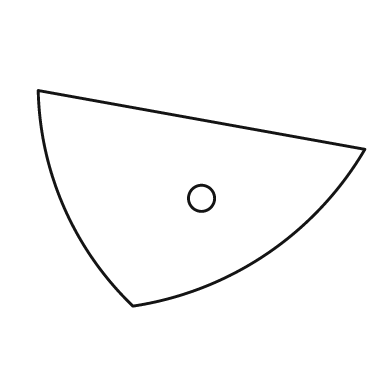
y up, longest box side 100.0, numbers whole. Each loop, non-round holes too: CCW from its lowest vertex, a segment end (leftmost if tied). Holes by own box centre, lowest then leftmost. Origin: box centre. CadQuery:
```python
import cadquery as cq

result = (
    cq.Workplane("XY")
    .moveTo(-21.0, -33.0)
    .threePointArc((20.0, -17.0), (50.0, 15.0))
    .lineTo(-50.0, 33.0)
    .threePointArc((-42.0, -3.0), (-21.0, -33.0))
    .close()
    .moveTo(0.0, 0.0)
    .circle(4.0)
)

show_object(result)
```